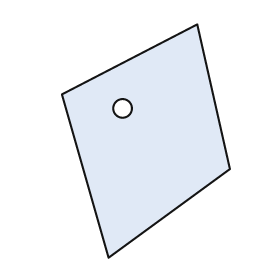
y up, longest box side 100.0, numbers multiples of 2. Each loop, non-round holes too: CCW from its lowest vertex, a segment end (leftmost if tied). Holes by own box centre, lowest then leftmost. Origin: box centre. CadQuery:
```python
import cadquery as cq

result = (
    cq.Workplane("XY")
    .moveTo(-16.0, -50.0)
    .lineTo(36.0, -12.0)
    .lineTo(22.0, 50.0)
    .lineTo(-36.0, 20.0)
    .close()
    .moveTo(-10.0, 14.0)
    .circle(4.0)
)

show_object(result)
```